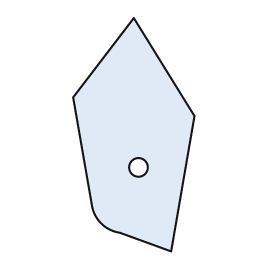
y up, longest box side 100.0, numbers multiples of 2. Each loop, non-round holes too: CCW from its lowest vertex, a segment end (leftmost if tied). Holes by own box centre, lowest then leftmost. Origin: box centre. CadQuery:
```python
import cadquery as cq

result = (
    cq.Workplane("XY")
    .moveTo(16.0, -50.0)
    .lineTo(26.0, 8.0)
    .lineTo(0.0, 50.0)
    .lineTo(-26.0, 16.0)
    .lineTo(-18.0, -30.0)
    .threePointArc((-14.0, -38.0), (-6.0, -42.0))
    .close()
    .moveTo(2.0, -14.0)
    .circle(4.0)
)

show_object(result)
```